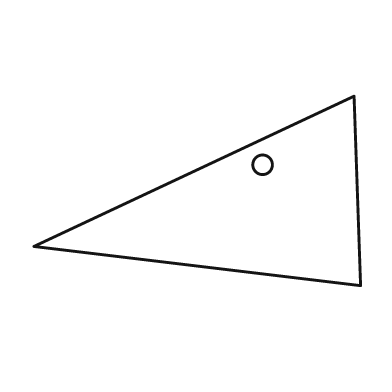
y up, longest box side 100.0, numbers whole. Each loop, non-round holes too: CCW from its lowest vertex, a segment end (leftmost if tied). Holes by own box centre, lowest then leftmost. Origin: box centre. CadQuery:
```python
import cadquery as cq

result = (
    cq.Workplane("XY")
    .moveTo(50.0, -29.0)
    .lineTo(48.0, 29.0)
    .lineTo(-50.0, -17.0)
    .close()
    .moveTo(20.0, 8.0)
    .circle(3.0)
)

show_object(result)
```